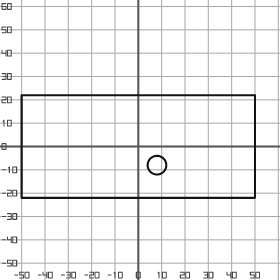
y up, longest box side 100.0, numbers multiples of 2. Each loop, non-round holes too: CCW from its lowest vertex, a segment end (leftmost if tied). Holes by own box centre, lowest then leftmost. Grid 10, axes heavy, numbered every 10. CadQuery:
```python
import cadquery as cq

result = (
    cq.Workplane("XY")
    .moveTo(-50.0, -22.0)
    .lineTo(50.0, -22.0)
    .lineTo(50.0, 22.0)
    .lineTo(-50.0, 22.0)
    .close()
    .moveTo(8.0, -8.0)
    .circle(4.0)
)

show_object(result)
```